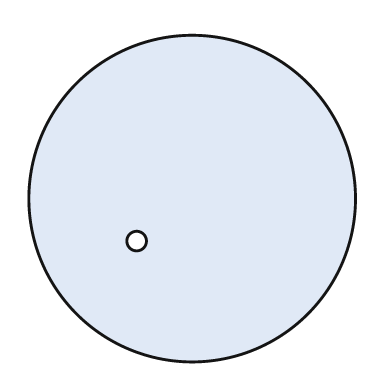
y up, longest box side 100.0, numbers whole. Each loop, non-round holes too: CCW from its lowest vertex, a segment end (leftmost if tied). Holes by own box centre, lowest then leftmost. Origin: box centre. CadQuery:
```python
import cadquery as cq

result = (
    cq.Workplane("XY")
    .moveTo(0.0, 0.0)
    .circle(50.0)
    .moveTo(-17.0, -13.0)
    .circle(3.0)
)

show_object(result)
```